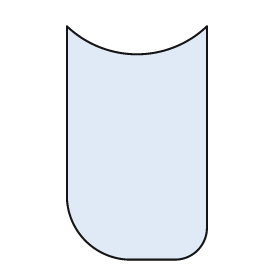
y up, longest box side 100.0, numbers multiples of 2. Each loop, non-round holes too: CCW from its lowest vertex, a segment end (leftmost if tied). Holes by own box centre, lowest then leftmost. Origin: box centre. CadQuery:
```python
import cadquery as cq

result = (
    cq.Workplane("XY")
    .moveTo(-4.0, -50.0)
    .lineTo(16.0, -50.0)
    .threePointArc((26.0, -46.0), (30.0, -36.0))
    .lineTo(30.0, 50.0)
    .threePointArc((0.0, 38.0), (-30.0, 50.0))
    .lineTo(-30.0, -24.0)
    .threePointArc((-22.0, -42.0), (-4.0, -50.0))
    .close()
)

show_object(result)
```